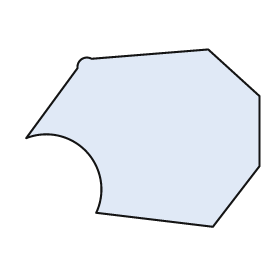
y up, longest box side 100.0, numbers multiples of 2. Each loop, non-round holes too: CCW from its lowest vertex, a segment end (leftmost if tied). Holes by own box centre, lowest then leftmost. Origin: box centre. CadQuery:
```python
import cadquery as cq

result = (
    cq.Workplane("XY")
    .moveTo(30.0, -38.0)
    .lineTo(50.0, -12.0)
    .lineTo(50.0, 18.0)
    .lineTo(28.0, 38.0)
    .lineTo(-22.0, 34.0)
    .threePointArc((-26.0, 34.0), (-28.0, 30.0))
    .lineTo(-50.0, 0.0)
    .threePointArc((-24.0, -6.0), (-20.0, -32.0))
    .close()
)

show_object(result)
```